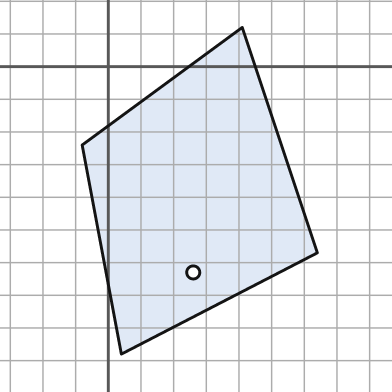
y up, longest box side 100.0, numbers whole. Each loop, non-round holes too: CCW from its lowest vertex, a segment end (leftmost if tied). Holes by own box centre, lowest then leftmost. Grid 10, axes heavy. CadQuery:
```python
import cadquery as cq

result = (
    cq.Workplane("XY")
    .moveTo(4.0, -88.0)
    .lineTo(64.0, -57.0)
    .lineTo(41.0, 12.0)
    .lineTo(-8.0, -24.0)
    .close()
    .moveTo(26.0, -63.0)
    .circle(2.0)
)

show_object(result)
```